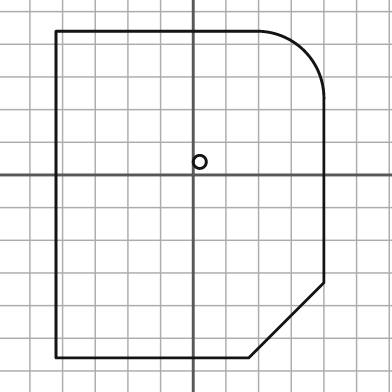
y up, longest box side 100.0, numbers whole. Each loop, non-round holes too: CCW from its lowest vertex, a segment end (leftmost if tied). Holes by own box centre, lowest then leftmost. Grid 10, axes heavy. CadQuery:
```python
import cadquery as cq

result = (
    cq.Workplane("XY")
    .moveTo(-42.0, -56.0)
    .lineTo(17.0, -56.0)
    .lineTo(40.0, -33.0)
    .lineTo(40.0, 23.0)
    .threePointArc((34.0, 38.0), (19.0, 44.0))
    .lineTo(-42.0, 44.0)
    .close()
    .moveTo(2.0, 4.0)
    .circle(2.0)
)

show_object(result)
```